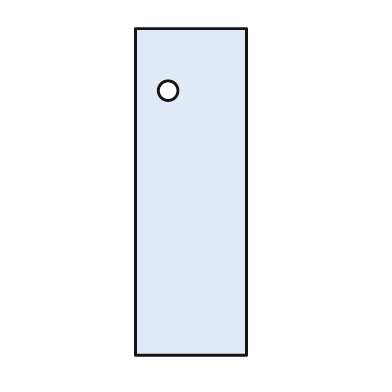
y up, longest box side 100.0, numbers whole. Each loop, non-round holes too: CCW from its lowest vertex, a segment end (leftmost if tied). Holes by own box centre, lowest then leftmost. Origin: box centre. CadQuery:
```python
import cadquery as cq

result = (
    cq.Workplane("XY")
    .moveTo(-17.0, -50.0)
    .lineTo(17.0, -50.0)
    .lineTo(17.0, 50.0)
    .lineTo(-17.0, 50.0)
    .close()
    .moveTo(-7.0, 31.0)
    .circle(3.0)
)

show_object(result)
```